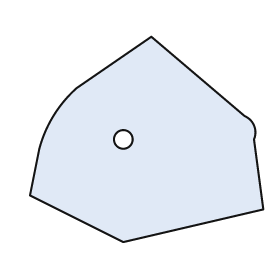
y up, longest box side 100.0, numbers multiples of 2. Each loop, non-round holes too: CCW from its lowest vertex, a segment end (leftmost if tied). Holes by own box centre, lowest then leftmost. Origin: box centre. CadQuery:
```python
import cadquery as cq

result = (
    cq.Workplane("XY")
    .moveTo(-10.0, -44.0)
    .lineTo(50.0, -30.0)
    .lineTo(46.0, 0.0)
    .threePointArc((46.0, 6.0), (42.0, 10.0))
    .lineTo(2.0, 44.0)
    .lineTo(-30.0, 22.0)
    .threePointArc((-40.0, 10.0), (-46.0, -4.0))
    .lineTo(-50.0, -24.0)
    .close()
    .moveTo(-10.0, 0.0)
    .circle(4.0)
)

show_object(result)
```